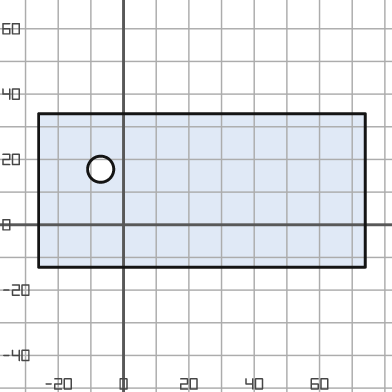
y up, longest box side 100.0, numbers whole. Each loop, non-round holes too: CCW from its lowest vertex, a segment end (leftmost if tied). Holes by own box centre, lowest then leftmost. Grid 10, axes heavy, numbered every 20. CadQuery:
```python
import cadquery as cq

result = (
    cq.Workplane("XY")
    .moveTo(-26.0, -13.0)
    .lineTo(74.0, -13.0)
    .lineTo(74.0, 34.0)
    .lineTo(-26.0, 34.0)
    .close()
    .moveTo(-7.0, 17.0)
    .circle(4.0)
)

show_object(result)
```